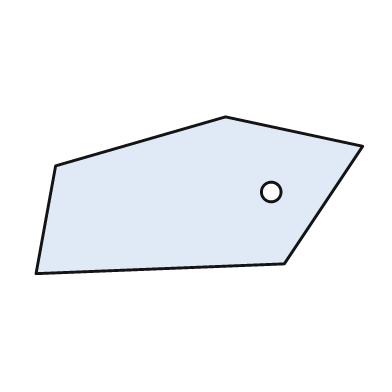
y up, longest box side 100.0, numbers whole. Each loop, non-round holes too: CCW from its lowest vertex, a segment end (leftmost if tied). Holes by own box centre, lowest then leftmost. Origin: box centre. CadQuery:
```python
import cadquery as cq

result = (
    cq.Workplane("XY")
    .moveTo(-50.0, -24.0)
    .lineTo(26.0, -21.0)
    .lineTo(50.0, 15.0)
    .lineTo(8.0, 24.0)
    .lineTo(-44.0, 9.0)
    .close()
    .moveTo(22.0, 1.0)
    .circle(3.0)
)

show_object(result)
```